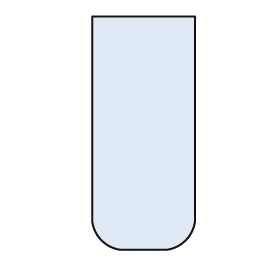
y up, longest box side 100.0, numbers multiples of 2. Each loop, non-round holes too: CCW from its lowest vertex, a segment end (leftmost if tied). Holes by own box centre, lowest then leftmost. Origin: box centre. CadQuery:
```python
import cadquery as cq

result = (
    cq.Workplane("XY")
    .moveTo(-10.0, -50.0)
    .lineTo(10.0, -50.0)
    .threePointArc((18.0, -46.0), (22.0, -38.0))
    .lineTo(22.0, 50.0)
    .lineTo(-22.0, 50.0)
    .lineTo(-22.0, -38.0)
    .threePointArc((-18.0, -46.0), (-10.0, -50.0))
    .close()
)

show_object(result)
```